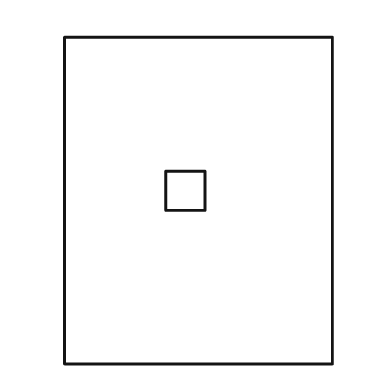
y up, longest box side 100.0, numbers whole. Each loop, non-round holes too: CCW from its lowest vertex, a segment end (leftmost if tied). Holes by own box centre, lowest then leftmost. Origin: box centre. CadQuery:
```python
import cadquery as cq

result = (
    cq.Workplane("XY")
    .moveTo(-41.0, -50.0)
    .lineTo(41.0, -50.0)
    .lineTo(41.0, 50.0)
    .lineTo(-41.0, 50.0)
    .close()
    .moveTo(-10.0, -3.0)
    .lineTo(2.0, -3.0)
    .lineTo(2.0, 9.0)
    .lineTo(-10.0, 9.0)
    .close()
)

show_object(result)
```